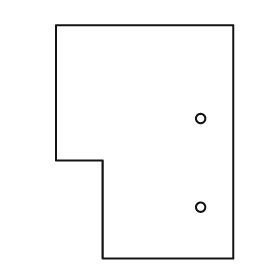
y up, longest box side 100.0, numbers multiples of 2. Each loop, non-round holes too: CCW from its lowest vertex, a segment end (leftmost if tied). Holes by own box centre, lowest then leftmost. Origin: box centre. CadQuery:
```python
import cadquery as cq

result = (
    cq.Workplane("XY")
    .moveTo(-18.0, -50.0)
    .lineTo(38.0, -50.0)
    .lineTo(38.0, 50.0)
    .lineTo(-38.0, 50.0)
    .lineTo(-38.0, -8.0)
    .lineTo(-18.0, -8.0)
    .close()
    .moveTo(24.0, -28.0)
    .circle(2.0)
    .moveTo(24.0, 10.0)
    .circle(2.0)
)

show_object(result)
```